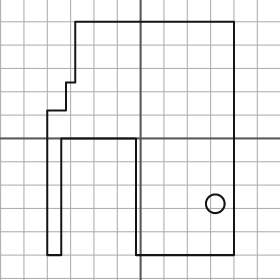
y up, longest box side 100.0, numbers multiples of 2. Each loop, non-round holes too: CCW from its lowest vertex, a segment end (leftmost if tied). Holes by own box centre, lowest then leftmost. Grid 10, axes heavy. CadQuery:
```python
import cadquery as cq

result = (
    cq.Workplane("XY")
    .moveTo(-40.0, -50.0)
    .lineTo(-34.0, -50.0)
    .lineTo(-34.0, 0.0)
    .lineTo(-2.0, 0.0)
    .lineTo(-2.0, -50.0)
    .lineTo(40.0, -50.0)
    .lineTo(40.0, 50.0)
    .lineTo(-28.0, 50.0)
    .lineTo(-28.0, 24.0)
    .lineTo(-32.0, 24.0)
    .lineTo(-32.0, 12.0)
    .lineTo(-40.0, 12.0)
    .close()
    .moveTo(32.0, -28.0)
    .circle(4.0)
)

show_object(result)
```